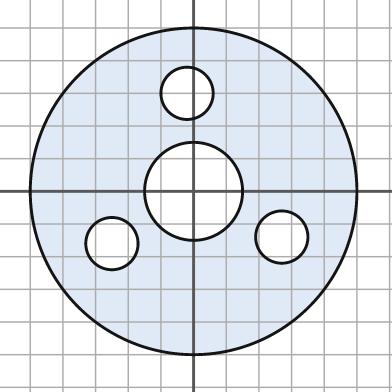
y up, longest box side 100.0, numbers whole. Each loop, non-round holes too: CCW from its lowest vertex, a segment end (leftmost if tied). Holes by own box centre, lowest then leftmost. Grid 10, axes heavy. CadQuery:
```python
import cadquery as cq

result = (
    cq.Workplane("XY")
    .moveTo(0.0, 0.0)
    .circle(50.0)
    .moveTo(-25.0, -16.0)
    .circle(8.0)
    .moveTo(27.0, -14.0)
    .circle(8.0)
    .moveTo(0.0, 0.0)
    .circle(15.0)
    .moveTo(-2.0, 30.0)
    .circle(8.0)
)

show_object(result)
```